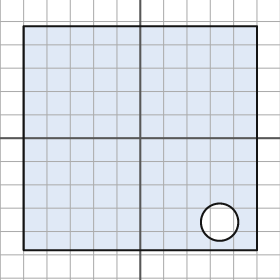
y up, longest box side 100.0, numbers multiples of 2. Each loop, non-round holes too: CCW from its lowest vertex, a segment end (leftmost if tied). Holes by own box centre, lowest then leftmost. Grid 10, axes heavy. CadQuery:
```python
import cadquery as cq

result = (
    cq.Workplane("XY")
    .moveTo(-50.0, -48.0)
    .lineTo(50.0, -48.0)
    .lineTo(50.0, 48.0)
    .lineTo(-50.0, 48.0)
    .close()
    .moveTo(34.0, -36.0)
    .circle(8.0)
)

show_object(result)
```